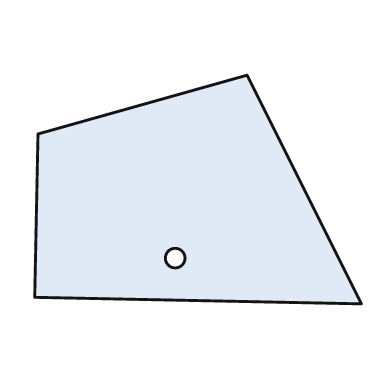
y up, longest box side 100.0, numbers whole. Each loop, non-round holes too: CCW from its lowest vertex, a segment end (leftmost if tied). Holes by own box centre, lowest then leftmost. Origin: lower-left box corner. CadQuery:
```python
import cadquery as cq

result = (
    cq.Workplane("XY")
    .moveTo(100.0, 0.0)
    .lineTo(65.0, 70.0)
    .lineTo(1.0, 52.0)
    .lineTo(0.0, 2.0)
    .close()
    .moveTo(43.0, 14.0)
    .circle(3.0)
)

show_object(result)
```